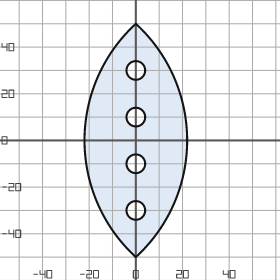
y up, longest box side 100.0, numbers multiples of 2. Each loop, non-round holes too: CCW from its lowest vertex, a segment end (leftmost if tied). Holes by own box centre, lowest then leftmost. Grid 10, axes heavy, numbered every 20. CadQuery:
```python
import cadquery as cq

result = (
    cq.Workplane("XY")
    .moveTo(0.0, -50.0)
    .threePointArc((22.0, 0.0), (0.0, 50.0))
    .threePointArc((-22.0, 0.0), (0.0, -50.0))
    .close()
    .moveTo(0.0, -30.0)
    .circle(4.0)
    .moveTo(0.0, -10.0)
    .circle(4.0)
    .moveTo(0.0, 10.0)
    .circle(4.0)
    .moveTo(0.0, 30.0)
    .circle(4.0)
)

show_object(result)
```